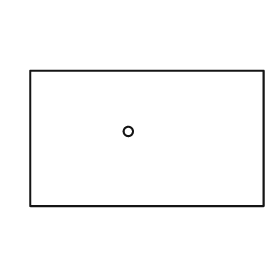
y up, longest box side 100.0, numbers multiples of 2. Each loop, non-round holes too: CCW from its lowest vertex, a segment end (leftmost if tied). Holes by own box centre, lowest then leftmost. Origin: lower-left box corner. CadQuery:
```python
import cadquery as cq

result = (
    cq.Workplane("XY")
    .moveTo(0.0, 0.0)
    .lineTo(100.0, 0.0)
    .lineTo(100.0, 58.0)
    .lineTo(0.0, 58.0)
    .close()
    .moveTo(42.0, 32.0)
    .circle(2.0)
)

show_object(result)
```